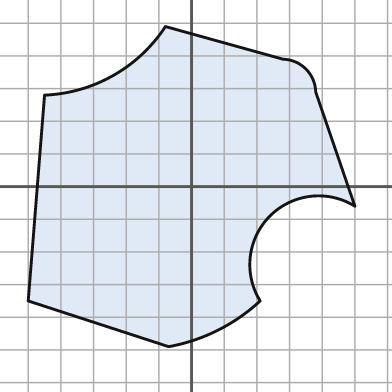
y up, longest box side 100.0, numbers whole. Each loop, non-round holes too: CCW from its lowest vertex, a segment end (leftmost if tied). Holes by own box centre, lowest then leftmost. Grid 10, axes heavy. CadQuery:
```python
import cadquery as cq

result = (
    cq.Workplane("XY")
    .moveTo(-7.0, -49.0)
    .threePointArc((8.0, -44.0), (21.0, -35.0))
    .threePointArc((24.0, -9.0), (50.0, -6.0))
    .lineTo(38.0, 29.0)
    .threePointArc((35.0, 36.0), (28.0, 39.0))
    .lineTo(-8.0, 49.0)
    .threePointArc((-24.0, 34.0), (-45.0, 28.0))
    .lineTo(-50.0, -35.0)
    .close()
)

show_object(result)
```